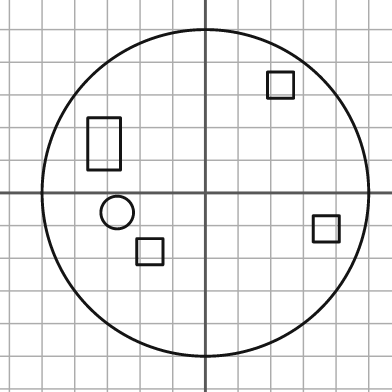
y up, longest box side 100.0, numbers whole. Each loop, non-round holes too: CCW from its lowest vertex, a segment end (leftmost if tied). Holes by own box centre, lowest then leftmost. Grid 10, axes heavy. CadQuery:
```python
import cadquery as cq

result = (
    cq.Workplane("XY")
    .moveTo(0.0, 0.0)
    .circle(50.0)
    .moveTo(-21.0, -22.0)
    .lineTo(-13.0, -22.0)
    .lineTo(-13.0, -14.0)
    .lineTo(-21.0, -14.0)
    .close()
    .moveTo(33.0, -15.0)
    .lineTo(41.0, -15.0)
    .lineTo(41.0, -7.0)
    .lineTo(33.0, -7.0)
    .close()
    .moveTo(-27.0, -6.0)
    .circle(5.0)
    .moveTo(-36.0, 7.0)
    .lineTo(-26.0, 7.0)
    .lineTo(-26.0, 23.0)
    .lineTo(-36.0, 23.0)
    .close()
    .moveTo(19.0, 29.0)
    .lineTo(27.0, 29.0)
    .lineTo(27.0, 37.0)
    .lineTo(19.0, 37.0)
    .close()
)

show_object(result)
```